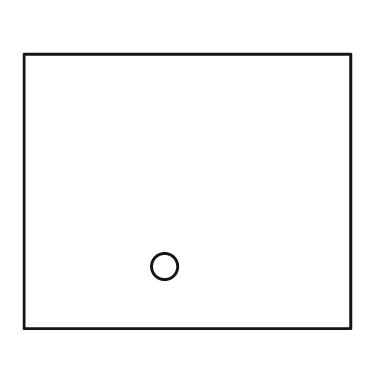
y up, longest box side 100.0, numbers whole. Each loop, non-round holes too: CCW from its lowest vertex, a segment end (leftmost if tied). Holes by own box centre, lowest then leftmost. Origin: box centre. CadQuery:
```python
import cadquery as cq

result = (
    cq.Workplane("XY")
    .moveTo(-50.0, -42.0)
    .lineTo(50.0, -42.0)
    .lineTo(50.0, 42.0)
    .lineTo(-50.0, 42.0)
    .close()
    .moveTo(-7.0, -23.0)
    .circle(4.0)
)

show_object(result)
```